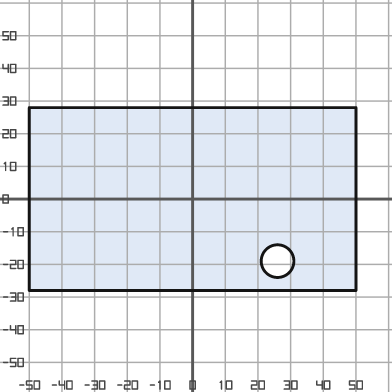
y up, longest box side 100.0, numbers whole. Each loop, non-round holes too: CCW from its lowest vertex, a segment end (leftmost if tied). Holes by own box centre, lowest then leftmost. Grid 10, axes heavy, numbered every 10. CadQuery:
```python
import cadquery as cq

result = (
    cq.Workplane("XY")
    .moveTo(-50.0, -28.0)
    .lineTo(50.0, -28.0)
    .lineTo(50.0, 28.0)
    .lineTo(-50.0, 28.0)
    .close()
    .moveTo(26.0, -19.0)
    .circle(5.0)
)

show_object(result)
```